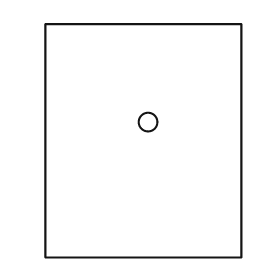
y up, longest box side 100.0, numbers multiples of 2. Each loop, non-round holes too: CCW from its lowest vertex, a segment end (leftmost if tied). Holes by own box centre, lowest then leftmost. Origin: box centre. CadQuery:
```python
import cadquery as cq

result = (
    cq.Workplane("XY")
    .moveTo(-42.0, -50.0)
    .lineTo(42.0, -50.0)
    .lineTo(42.0, 50.0)
    .lineTo(-42.0, 50.0)
    .close()
    .moveTo(2.0, 8.0)
    .circle(4.0)
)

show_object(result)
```